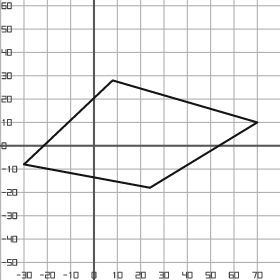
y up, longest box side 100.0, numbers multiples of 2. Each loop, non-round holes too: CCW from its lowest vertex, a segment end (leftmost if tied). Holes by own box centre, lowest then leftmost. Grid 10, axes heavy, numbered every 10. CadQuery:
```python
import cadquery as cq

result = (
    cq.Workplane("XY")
    .moveTo(24.0, -18.0)
    .lineTo(70.0, 10.0)
    .lineTo(8.0, 28.0)
    .lineTo(-30.0, -8.0)
    .close()
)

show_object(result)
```